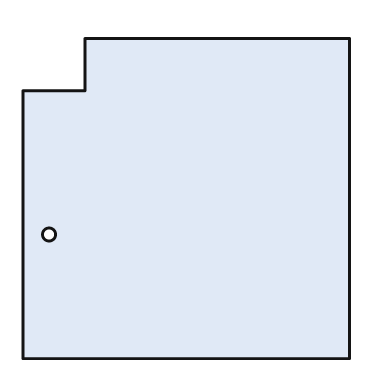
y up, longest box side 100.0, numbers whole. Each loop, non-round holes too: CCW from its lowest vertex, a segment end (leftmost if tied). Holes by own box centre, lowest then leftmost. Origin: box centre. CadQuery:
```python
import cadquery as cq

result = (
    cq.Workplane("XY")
    .moveTo(-50.0, -49.0)
    .lineTo(50.0, -49.0)
    .lineTo(50.0, 49.0)
    .lineTo(-31.0, 49.0)
    .lineTo(-31.0, 33.0)
    .lineTo(-50.0, 33.0)
    .close()
    .moveTo(-42.0, -11.0)
    .circle(2.0)
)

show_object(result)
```